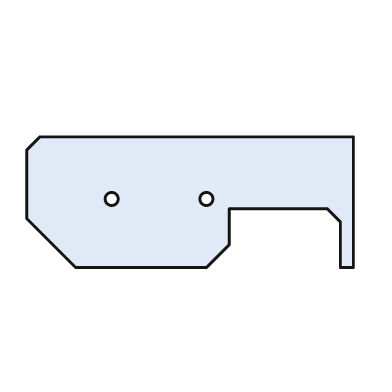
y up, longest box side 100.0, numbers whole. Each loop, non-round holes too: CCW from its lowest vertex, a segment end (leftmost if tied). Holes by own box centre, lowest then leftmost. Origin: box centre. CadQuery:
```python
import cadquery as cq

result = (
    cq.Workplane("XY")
    .moveTo(-35.0, -20.0)
    .lineTo(5.0, -20.0)
    .lineTo(12.0, -13.0)
    .lineTo(12.0, -2.0)
    .lineTo(42.0, -2.0)
    .lineTo(46.0, -6.0)
    .lineTo(46.0, -20.0)
    .lineTo(50.0, -20.0)
    .lineTo(50.0, 20.0)
    .lineTo(-46.0, 20.0)
    .lineTo(-50.0, 16.0)
    .lineTo(-50.0, -5.0)
    .close()
    .moveTo(-24.0, 1.0)
    .circle(2.0)
    .moveTo(5.0, 1.0)
    .circle(2.0)
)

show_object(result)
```